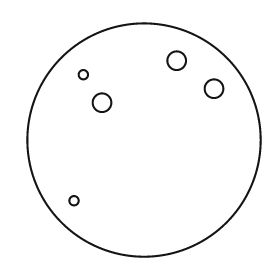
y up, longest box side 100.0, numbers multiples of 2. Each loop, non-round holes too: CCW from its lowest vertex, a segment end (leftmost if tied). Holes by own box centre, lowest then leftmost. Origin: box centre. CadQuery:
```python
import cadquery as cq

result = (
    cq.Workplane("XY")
    .moveTo(0.0, 0.0)
    .circle(50.0)
    .moveTo(-30.0, -26.0)
    .circle(2.0)
    .moveTo(-18.0, 16.0)
    .circle(4.0)
    .moveTo(30.0, 22.0)
    .circle(4.0)
    .moveTo(-26.0, 28.0)
    .circle(2.0)
    .moveTo(14.0, 34.0)
    .circle(4.0)
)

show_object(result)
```